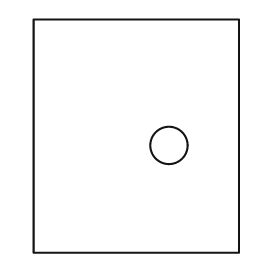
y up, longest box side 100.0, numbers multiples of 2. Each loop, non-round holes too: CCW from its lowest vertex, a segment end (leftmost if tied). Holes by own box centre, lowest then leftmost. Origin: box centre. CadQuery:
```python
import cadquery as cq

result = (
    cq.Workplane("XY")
    .moveTo(-44.0, -50.0)
    .lineTo(44.0, -50.0)
    .lineTo(44.0, 50.0)
    .lineTo(-44.0, 50.0)
    .close()
    .moveTo(14.0, -4.0)
    .circle(8.0)
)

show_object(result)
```